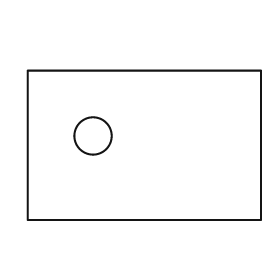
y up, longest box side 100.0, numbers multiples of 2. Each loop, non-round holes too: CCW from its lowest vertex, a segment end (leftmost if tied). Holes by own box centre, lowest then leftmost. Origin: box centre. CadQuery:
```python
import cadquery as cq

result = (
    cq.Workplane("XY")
    .moveTo(-50.0, -32.0)
    .lineTo(50.0, -32.0)
    .lineTo(50.0, 32.0)
    .lineTo(-50.0, 32.0)
    .close()
    .moveTo(-22.0, 4.0)
    .circle(8.0)
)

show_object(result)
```